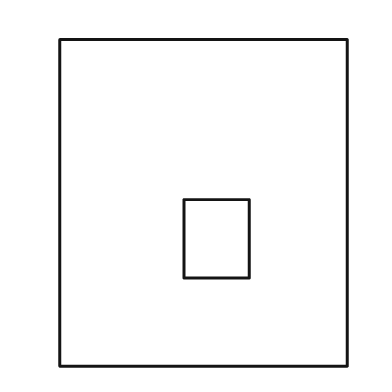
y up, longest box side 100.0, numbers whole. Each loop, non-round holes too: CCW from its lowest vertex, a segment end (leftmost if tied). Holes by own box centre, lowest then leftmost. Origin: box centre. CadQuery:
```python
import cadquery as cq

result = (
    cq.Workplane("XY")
    .moveTo(-44.0, -50.0)
    .lineTo(44.0, -50.0)
    .lineTo(44.0, 50.0)
    .lineTo(-44.0, 50.0)
    .close()
    .moveTo(-6.0, -23.0)
    .lineTo(14.0, -23.0)
    .lineTo(14.0, 1.0)
    .lineTo(-6.0, 1.0)
    .close()
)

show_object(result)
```